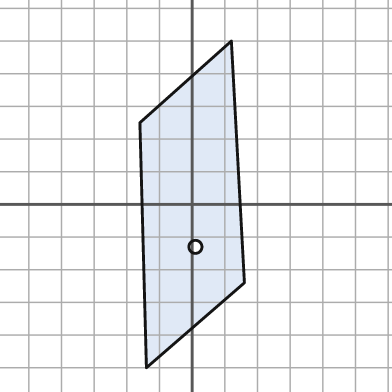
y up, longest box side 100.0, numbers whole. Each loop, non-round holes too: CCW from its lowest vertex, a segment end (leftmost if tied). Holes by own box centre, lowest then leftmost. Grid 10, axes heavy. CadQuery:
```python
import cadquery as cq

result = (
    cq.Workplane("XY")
    .moveTo(-14.0, -50.0)
    .lineTo(16.0, -24.0)
    .lineTo(12.0, 50.0)
    .lineTo(-16.0, 25.0)
    .close()
    .moveTo(1.0, -13.0)
    .circle(2.0)
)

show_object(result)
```